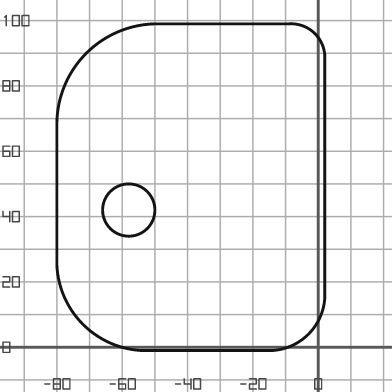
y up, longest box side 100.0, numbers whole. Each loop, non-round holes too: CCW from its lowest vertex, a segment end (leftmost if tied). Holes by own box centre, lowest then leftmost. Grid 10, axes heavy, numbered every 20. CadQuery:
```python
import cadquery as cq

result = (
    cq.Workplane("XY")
    .moveTo(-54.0, -1.0)
    .lineTo(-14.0, -1.0)
    .threePointArc((-3.0, 4.0), (2.0, 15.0))
    .lineTo(2.0, 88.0)
    .threePointArc((-1.0, 96.0), (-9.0, 99.0))
    .lineTo(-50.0, 99.0)
    .threePointArc((-71.0, 90.0), (-80.0, 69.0))
    .lineTo(-80.0, 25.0)
    .threePointArc((-72.0, 7.0), (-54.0, -1.0))
    .close()
    .moveTo(-58.0, 42.0)
    .circle(8.0)
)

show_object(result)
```